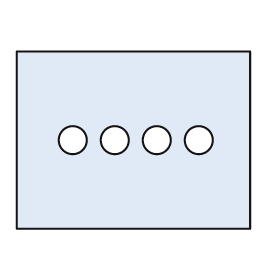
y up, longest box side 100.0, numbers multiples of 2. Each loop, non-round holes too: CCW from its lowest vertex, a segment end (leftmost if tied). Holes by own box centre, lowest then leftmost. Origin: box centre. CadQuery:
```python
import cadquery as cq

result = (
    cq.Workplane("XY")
    .moveTo(-50.0, -38.0)
    .lineTo(50.0, -38.0)
    .lineTo(50.0, 38.0)
    .lineTo(-50.0, 38.0)
    .close()
    .moveTo(-26.0, 0.0)
    .circle(6.0)
    .moveTo(-8.0, 0.0)
    .circle(6.0)
    .moveTo(10.0, 0.0)
    .circle(6.0)
    .moveTo(28.0, 0.0)
    .circle(6.0)
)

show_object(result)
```